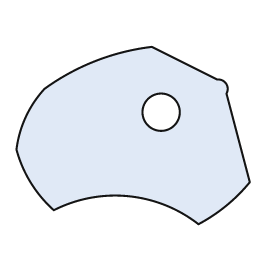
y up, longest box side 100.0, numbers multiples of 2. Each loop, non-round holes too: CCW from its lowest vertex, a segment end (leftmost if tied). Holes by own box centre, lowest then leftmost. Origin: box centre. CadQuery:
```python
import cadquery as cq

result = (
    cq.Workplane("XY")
    .moveTo(28.0, -38.0)
    .threePointArc((40.0, -30.0), (50.0, -20.0))
    .lineTo(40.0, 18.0)
    .threePointArc((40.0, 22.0), (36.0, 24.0))
    .lineTo(8.0, 38.0)
    .threePointArc((-16.0, 32.0), (-38.0, 20.0))
    .threePointArc((-46.0, 8.0), (-50.0, -6.0))
    .threePointArc((-44.0, -20.0), (-34.0, -32.0))
    .threePointArc((-2.0, -26.0), (28.0, -38.0))
    .close()
    .moveTo(12.0, 10.0)
    .circle(8.0)
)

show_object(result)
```